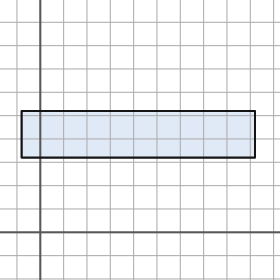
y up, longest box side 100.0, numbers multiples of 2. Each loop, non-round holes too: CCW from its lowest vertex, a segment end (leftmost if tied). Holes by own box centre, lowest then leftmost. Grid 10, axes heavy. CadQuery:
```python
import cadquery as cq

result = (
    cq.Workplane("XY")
    .moveTo(-8.0, 32.0)
    .lineTo(92.0, 32.0)
    .lineTo(92.0, 52.0)
    .lineTo(-8.0, 52.0)
    .close()
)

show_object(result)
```